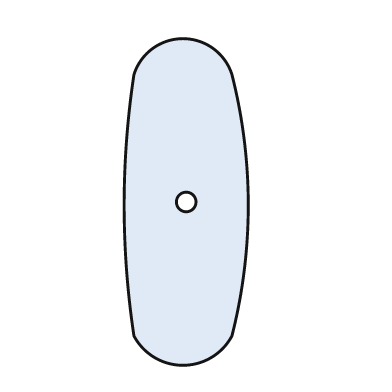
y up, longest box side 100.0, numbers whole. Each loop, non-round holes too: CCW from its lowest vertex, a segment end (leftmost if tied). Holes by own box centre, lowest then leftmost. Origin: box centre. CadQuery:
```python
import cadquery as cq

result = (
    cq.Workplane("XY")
    .moveTo(-16.0, -41.0)
    .threePointArc((-1.0, -50.0), (14.0, -41.0))
    .threePointArc((19.0, -1.0), (14.0, 39.0))
    .threePointArc((-1.0, 50.0), (-16.0, 39.0))
    .threePointArc((-19.0, -1.0), (-16.0, -41.0))
    .close()
    .moveTo(0.0, 0.0)
    .circle(3.0)
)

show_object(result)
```